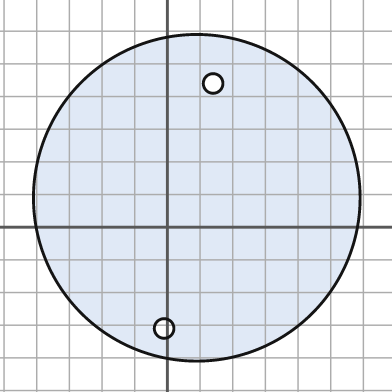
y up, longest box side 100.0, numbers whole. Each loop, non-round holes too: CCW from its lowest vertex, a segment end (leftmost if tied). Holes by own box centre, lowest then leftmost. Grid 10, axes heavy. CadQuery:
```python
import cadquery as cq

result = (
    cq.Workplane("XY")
    .moveTo(9.0, 9.0)
    .circle(50.0)
    .moveTo(-1.0, -31.0)
    .circle(3.0)
    .moveTo(14.0, 44.0)
    .circle(3.0)
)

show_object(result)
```